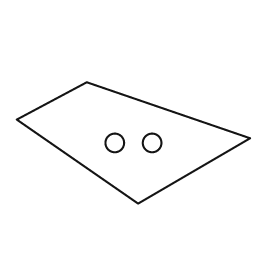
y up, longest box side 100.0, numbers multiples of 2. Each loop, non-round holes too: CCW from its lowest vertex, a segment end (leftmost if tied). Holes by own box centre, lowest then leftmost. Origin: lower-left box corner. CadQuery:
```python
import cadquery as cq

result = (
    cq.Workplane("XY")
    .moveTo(52.0, 0.0)
    .lineTo(100.0, 28.0)
    .lineTo(30.0, 52.0)
    .lineTo(0.0, 36.0)
    .close()
    .moveTo(42.0, 26.0)
    .circle(4.0)
    .moveTo(58.0, 26.0)
    .circle(4.0)
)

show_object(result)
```